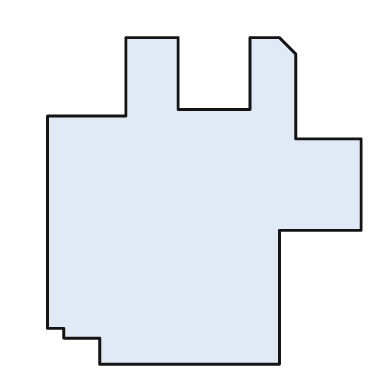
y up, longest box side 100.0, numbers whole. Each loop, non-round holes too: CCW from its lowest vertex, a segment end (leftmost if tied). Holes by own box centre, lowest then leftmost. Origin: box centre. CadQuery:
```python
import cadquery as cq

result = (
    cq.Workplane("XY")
    .moveTo(-32.0, -50.0)
    .lineTo(23.0, -50.0)
    .lineTo(23.0, -9.0)
    .lineTo(48.0, -9.0)
    .lineTo(48.0, 19.0)
    .lineTo(28.0, 19.0)
    .lineTo(28.0, 45.0)
    .lineTo(23.0, 50.0)
    .lineTo(14.0, 50.0)
    .lineTo(14.0, 28.0)
    .lineTo(-8.0, 28.0)
    .lineTo(-8.0, 50.0)
    .lineTo(-24.0, 50.0)
    .lineTo(-24.0, 26.0)
    .lineTo(-48.0, 26.0)
    .lineTo(-48.0, -39.0)
    .lineTo(-43.0, -39.0)
    .lineTo(-43.0, -42.0)
    .lineTo(-32.0, -42.0)
    .close()
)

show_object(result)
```